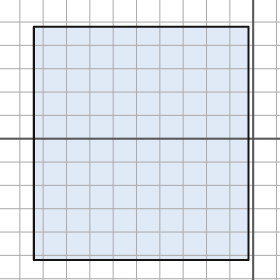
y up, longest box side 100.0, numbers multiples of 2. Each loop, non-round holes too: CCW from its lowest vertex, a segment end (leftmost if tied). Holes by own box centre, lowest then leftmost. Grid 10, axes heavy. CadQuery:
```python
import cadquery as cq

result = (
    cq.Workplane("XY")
    .moveTo(-94.0, -52.0)
    .lineTo(-2.0, -52.0)
    .lineTo(-2.0, 48.0)
    .lineTo(-94.0, 48.0)
    .close()
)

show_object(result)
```